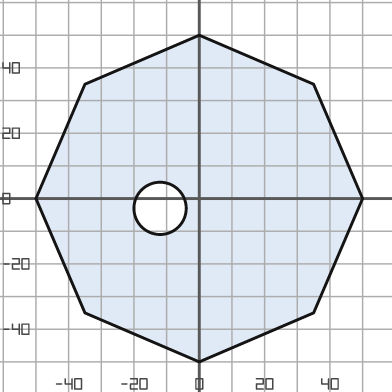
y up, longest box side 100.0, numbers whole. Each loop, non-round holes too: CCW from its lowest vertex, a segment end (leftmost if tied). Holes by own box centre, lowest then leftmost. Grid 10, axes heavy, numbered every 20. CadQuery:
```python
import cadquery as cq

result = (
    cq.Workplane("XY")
    .moveTo(0.0, -50.0)
    .lineTo(35.0, -35.0)
    .lineTo(50.0, 0.0)
    .lineTo(35.0, 35.0)
    .lineTo(0.0, 50.0)
    .lineTo(-35.0, 35.0)
    .lineTo(-50.0, 0.0)
    .lineTo(-35.0, -35.0)
    .close()
    .moveTo(-12.0, -3.0)
    .circle(8.0)
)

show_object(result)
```